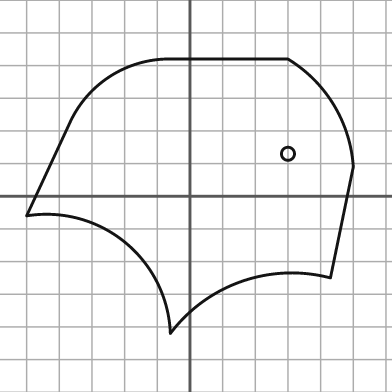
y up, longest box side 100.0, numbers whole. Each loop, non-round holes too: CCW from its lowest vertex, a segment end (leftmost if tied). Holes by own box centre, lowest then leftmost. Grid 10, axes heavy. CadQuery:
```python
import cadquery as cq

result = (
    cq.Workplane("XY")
    .moveTo(-6.0, -42.0)
    .threePointArc((16.0, -26.0), (43.0, -25.0))
    .lineTo(50.0, 9.0)
    .threePointArc((44.0, 28.0), (30.0, 42.0))
    .lineTo(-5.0, 42.0)
    .threePointArc((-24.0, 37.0), (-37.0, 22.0))
    .lineTo(-50.0, -6.0)
    .threePointArc((-20.0, -14.0), (-6.0, -42.0))
    .close()
    .moveTo(30.0, 13.0)
    .circle(2.0)
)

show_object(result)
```